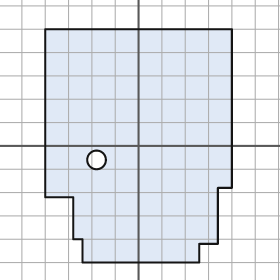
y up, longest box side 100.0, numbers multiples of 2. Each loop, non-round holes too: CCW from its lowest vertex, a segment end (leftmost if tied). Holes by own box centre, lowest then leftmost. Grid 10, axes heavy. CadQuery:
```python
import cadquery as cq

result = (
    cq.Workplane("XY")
    .moveTo(-24.0, -50.0)
    .lineTo(26.0, -50.0)
    .lineTo(26.0, -42.0)
    .lineTo(34.0, -42.0)
    .lineTo(34.0, -18.0)
    .lineTo(40.0, -18.0)
    .lineTo(40.0, 50.0)
    .lineTo(-40.0, 50.0)
    .lineTo(-40.0, -22.0)
    .lineTo(-28.0, -22.0)
    .lineTo(-28.0, -40.0)
    .lineTo(-24.0, -40.0)
    .close()
    .moveTo(-18.0, -6.0)
    .circle(4.0)
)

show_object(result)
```